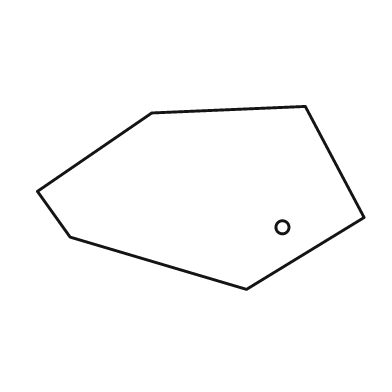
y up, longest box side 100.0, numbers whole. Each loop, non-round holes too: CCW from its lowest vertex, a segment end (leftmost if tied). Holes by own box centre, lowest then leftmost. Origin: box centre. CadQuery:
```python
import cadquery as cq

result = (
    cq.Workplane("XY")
    .moveTo(14.0, -28.0)
    .lineTo(50.0, -6.0)
    .lineTo(32.0, 28.0)
    .lineTo(-15.0, 26.0)
    .lineTo(-50.0, 2.0)
    .lineTo(-40.0, -12.0)
    .close()
    .moveTo(25.0, -9.0)
    .circle(2.0)
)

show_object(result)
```